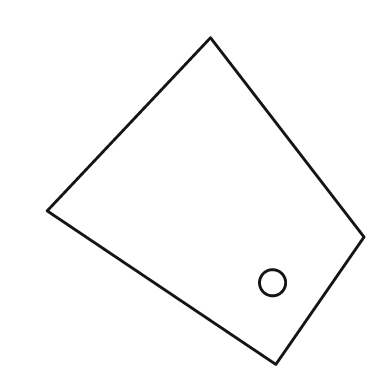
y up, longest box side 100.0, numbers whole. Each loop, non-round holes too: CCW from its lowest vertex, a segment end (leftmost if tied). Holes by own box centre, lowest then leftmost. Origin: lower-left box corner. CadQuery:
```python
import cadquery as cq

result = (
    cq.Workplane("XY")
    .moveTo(70.0, 0.0)
    .lineTo(97.0, 39.0)
    .lineTo(50.0, 100.0)
    .lineTo(0.0, 47.0)
    .close()
    .moveTo(69.0, 25.0)
    .circle(4.0)
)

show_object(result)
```